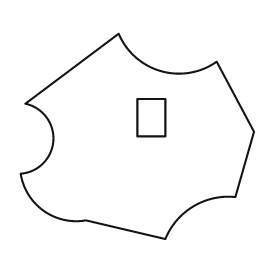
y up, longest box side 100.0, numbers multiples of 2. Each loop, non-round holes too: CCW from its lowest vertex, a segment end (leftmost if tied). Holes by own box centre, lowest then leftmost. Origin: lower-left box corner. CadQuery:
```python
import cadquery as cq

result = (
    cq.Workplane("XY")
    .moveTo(62.0, 0.0)
    .threePointArc((74.0, 14.0), (92.0, 18.0))
    .lineTo(100.0, 46.0)
    .lineTo(84.0, 76.0)
    .threePointArc((60.0, 72.0), (42.0, 88.0))
    .lineTo(2.0, 58.0)
    .threePointArc((14.0, 42.0), (0.0, 28.0))
    .threePointArc((10.0, 12.0), (28.0, 8.0))
    .close()
    .moveTo(50.0, 44.0)
    .lineTo(62.0, 44.0)
    .lineTo(62.0, 60.0)
    .lineTo(50.0, 60.0)
    .close()
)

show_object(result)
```